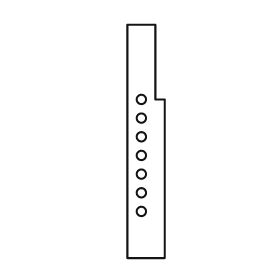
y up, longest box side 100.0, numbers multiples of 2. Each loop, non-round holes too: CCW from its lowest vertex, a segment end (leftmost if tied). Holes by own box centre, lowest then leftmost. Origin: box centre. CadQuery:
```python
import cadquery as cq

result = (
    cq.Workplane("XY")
    .moveTo(-8.0, -50.0)
    .lineTo(8.0, -50.0)
    .lineTo(8.0, 18.0)
    .lineTo(4.0, 18.0)
    .lineTo(4.0, 50.0)
    .lineTo(-8.0, 50.0)
    .close()
    .moveTo(-2.0, -30.0)
    .circle(2.0)
    .moveTo(-2.0, -22.0)
    .circle(2.0)
    .moveTo(-2.0, -14.0)
    .circle(2.0)
    .moveTo(-2.0, -6.0)
    .circle(2.0)
    .moveTo(-2.0, 2.0)
    .circle(2.0)
    .moveTo(-2.0, 10.0)
    .circle(2.0)
    .moveTo(-2.0, 18.0)
    .circle(2.0)
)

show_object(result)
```